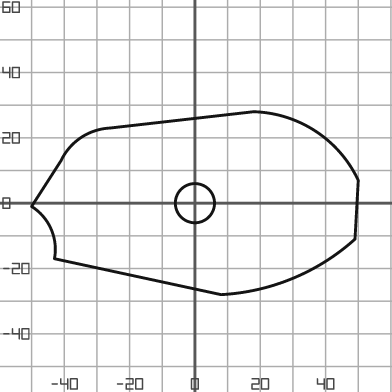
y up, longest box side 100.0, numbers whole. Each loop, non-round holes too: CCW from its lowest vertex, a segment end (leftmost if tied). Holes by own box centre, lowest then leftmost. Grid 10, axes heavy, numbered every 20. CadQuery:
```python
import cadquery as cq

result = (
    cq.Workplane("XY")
    .moveTo(8.0, -28.0)
    .threePointArc((30.0, -23.0), (49.0, -11.0))
    .lineTo(50.0, 7.0)
    .threePointArc((37.0, 22.0), (18.0, 28.0))
    .lineTo(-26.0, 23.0)
    .threePointArc((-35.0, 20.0), (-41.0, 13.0))
    .lineTo(-50.0, -1.0)
    .threePointArc((-44.0, -8.0), (-43.0, -17.0))
    .close()
    .moveTo(0.0, 0.0)
    .circle(6.0)
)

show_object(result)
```